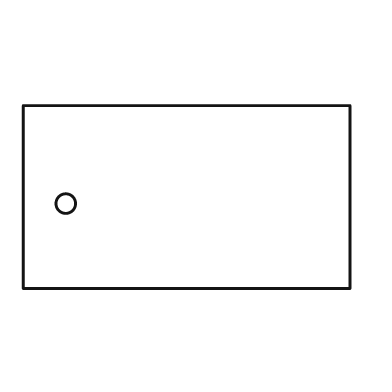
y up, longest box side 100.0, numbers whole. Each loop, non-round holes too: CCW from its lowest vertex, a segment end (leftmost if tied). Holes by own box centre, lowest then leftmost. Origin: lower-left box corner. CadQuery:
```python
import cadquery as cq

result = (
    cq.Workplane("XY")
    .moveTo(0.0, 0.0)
    .lineTo(100.0, 0.0)
    .lineTo(100.0, 56.0)
    .lineTo(0.0, 56.0)
    .close()
    .moveTo(13.0, 26.0)
    .circle(3.0)
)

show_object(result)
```